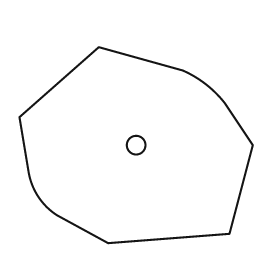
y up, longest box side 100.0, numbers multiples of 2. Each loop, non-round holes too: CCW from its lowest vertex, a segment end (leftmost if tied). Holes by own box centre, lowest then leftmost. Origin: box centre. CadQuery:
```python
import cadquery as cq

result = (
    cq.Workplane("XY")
    .moveTo(-12.0, -42.0)
    .lineTo(40.0, -38.0)
    .lineTo(50.0, 0.0)
    .lineTo(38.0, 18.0)
    .threePointArc((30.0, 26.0), (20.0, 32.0))
    .lineTo(-16.0, 42.0)
    .lineTo(-50.0, 12.0)
    .lineTo(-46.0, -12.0)
    .threePointArc((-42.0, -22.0), (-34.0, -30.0))
    .close()
    .moveTo(0.0, 0.0)
    .circle(4.0)
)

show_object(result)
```